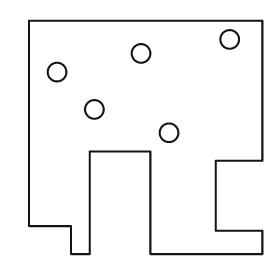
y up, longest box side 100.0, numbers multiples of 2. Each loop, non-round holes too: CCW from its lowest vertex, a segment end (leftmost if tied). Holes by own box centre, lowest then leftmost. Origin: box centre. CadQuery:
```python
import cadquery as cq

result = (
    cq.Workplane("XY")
    .moveTo(-32.0, -50.0)
    .lineTo(-24.0, -50.0)
    .lineTo(-24.0, -6.0)
    .lineTo(2.0, -6.0)
    .lineTo(2.0, -50.0)
    .lineTo(50.0, -50.0)
    .lineTo(50.0, -40.0)
    .lineTo(30.0, -40.0)
    .lineTo(30.0, -10.0)
    .lineTo(50.0, -10.0)
    .lineTo(50.0, 50.0)
    .lineTo(-50.0, 50.0)
    .lineTo(-50.0, -38.0)
    .lineTo(-32.0, -38.0)
    .close()
    .moveTo(10.0, 2.0)
    .circle(4.0)
    .moveTo(-22.0, 12.0)
    .circle(4.0)
    .moveTo(-38.0, 28.0)
    .circle(4.0)
    .moveTo(-2.0, 36.0)
    .circle(4.0)
    .moveTo(36.0, 42.0)
    .circle(4.0)
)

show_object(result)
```